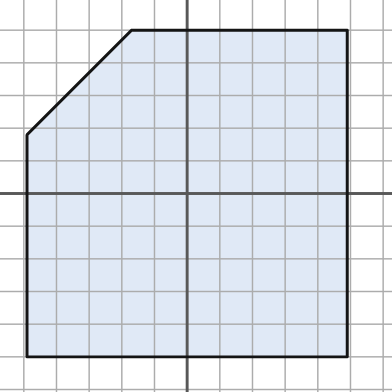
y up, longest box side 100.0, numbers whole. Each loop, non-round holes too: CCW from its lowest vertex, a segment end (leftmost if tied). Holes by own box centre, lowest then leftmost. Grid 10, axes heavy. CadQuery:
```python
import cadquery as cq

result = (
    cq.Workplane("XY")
    .moveTo(-49.0, -50.0)
    .lineTo(49.0, -50.0)
    .lineTo(49.0, 50.0)
    .lineTo(-17.0, 50.0)
    .lineTo(-49.0, 18.0)
    .close()
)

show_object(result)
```